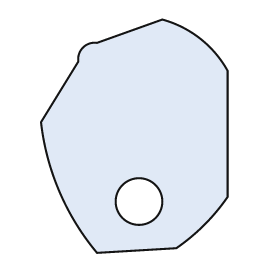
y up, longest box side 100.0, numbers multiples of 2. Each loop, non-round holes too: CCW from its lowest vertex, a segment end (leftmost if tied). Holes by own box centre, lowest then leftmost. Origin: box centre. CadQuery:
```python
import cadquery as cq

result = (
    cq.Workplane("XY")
    .moveTo(-16.0, -50.0)
    .lineTo(18.0, -48.0)
    .threePointArc((30.0, -38.0), (40.0, -26.0))
    .lineTo(40.0, 28.0)
    .threePointArc((28.0, 42.0), (12.0, 50.0))
    .lineTo(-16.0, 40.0)
    .threePointArc((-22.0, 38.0), (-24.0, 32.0))
    .lineTo(-40.0, 6.0)
    .threePointArc((-32.0, -24.0), (-16.0, -50.0))
    .close()
    .moveTo(2.0, -28.0)
    .circle(10.0)
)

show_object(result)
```